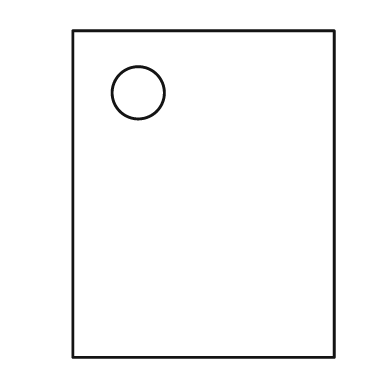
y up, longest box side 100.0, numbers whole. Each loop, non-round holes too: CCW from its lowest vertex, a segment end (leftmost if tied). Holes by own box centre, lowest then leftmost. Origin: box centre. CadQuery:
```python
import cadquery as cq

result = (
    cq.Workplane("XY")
    .moveTo(-40.0, -50.0)
    .lineTo(40.0, -50.0)
    .lineTo(40.0, 50.0)
    .lineTo(-40.0, 50.0)
    .close()
    .moveTo(-20.0, 31.0)
    .circle(8.0)
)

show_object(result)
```